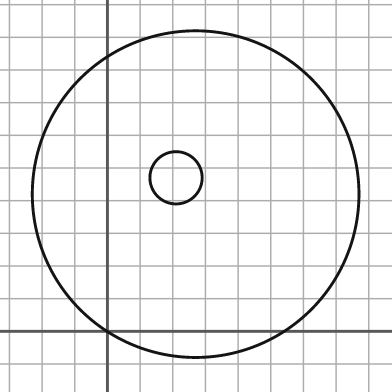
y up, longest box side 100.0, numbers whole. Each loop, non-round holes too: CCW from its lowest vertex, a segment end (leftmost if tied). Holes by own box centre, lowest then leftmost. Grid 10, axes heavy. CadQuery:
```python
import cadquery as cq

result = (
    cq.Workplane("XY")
    .moveTo(27.0, 42.0)
    .circle(50.0)
    .moveTo(21.0, 47.0)
    .circle(8.0)
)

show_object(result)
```